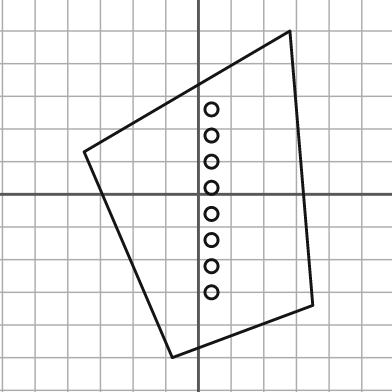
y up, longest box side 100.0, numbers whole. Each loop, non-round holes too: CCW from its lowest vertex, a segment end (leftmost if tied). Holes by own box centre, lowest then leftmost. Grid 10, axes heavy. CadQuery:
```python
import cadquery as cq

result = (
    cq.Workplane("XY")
    .moveTo(-8.0, -50.0)
    .lineTo(35.0, -34.0)
    .lineTo(28.0, 50.0)
    .lineTo(-35.0, 13.0)
    .close()
    .moveTo(4.0, -30.0)
    .circle(2.0)
    .moveTo(4.0, -22.0)
    .circle(2.0)
    .moveTo(4.0, -14.0)
    .circle(2.0)
    .moveTo(4.0, -6.0)
    .circle(2.0)
    .moveTo(4.0, 2.0)
    .circle(2.0)
    .moveTo(4.0, 10.0)
    .circle(2.0)
    .moveTo(4.0, 18.0)
    .circle(2.0)
    .moveTo(4.0, 26.0)
    .circle(2.0)
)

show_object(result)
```